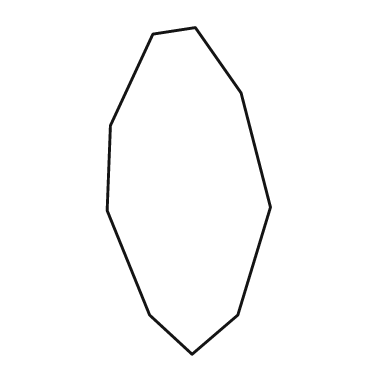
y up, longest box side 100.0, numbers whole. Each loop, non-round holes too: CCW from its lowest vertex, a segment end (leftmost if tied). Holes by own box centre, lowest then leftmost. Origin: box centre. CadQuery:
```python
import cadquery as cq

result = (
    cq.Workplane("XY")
    .moveTo(1.0, -50.0)
    .lineTo(15.0, -38.0)
    .lineTo(25.0, -5.0)
    .lineTo(16.0, 30.0)
    .lineTo(2.0, 50.0)
    .lineTo(-11.0, 48.0)
    .lineTo(-24.0, 20.0)
    .lineTo(-25.0, -6.0)
    .lineTo(-12.0, -38.0)
    .close()
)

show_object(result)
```